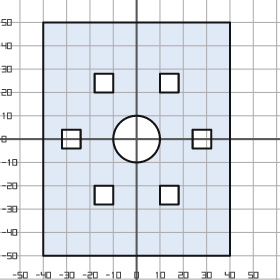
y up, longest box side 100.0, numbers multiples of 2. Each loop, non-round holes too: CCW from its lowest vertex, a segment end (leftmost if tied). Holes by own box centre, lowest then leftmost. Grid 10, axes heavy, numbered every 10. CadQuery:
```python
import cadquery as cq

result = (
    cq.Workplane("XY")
    .moveTo(-40.0, -50.0)
    .lineTo(40.0, -50.0)
    .lineTo(40.0, 50.0)
    .lineTo(-40.0, 50.0)
    .close()
    .moveTo(-18.0, -28.0)
    .lineTo(-10.0, -28.0)
    .lineTo(-10.0, -20.0)
    .lineTo(-18.0, -20.0)
    .close()
    .moveTo(10.0, -28.0)
    .lineTo(18.0, -28.0)
    .lineTo(18.0, -20.0)
    .lineTo(10.0, -20.0)
    .close()
    .moveTo(-32.0, -4.0)
    .lineTo(-24.0, -4.0)
    .lineTo(-24.0, 4.0)
    .lineTo(-32.0, 4.0)
    .close()
    .moveTo(0.0, 0.0)
    .circle(10.0)
    .moveTo(24.0, -4.0)
    .lineTo(32.0, -4.0)
    .lineTo(32.0, 4.0)
    .lineTo(24.0, 4.0)
    .close()
    .moveTo(-18.0, 20.0)
    .lineTo(-10.0, 20.0)
    .lineTo(-10.0, 28.0)
    .lineTo(-18.0, 28.0)
    .close()
    .moveTo(10.0, 20.0)
    .lineTo(18.0, 20.0)
    .lineTo(18.0, 28.0)
    .lineTo(10.0, 28.0)
    .close()
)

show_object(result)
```